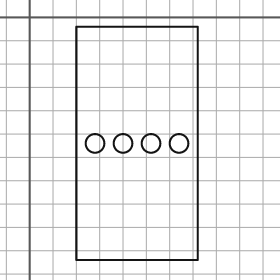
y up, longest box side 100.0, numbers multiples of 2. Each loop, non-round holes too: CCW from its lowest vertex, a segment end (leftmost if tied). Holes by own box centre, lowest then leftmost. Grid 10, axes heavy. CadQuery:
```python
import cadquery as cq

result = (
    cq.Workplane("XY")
    .moveTo(20.0, -104.0)
    .lineTo(72.0, -104.0)
    .lineTo(72.0, -4.0)
    .lineTo(20.0, -4.0)
    .close()
    .moveTo(28.0, -54.0)
    .circle(4.0)
    .moveTo(40.0, -54.0)
    .circle(4.0)
    .moveTo(52.0, -54.0)
    .circle(4.0)
    .moveTo(64.0, -54.0)
    .circle(4.0)
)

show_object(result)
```